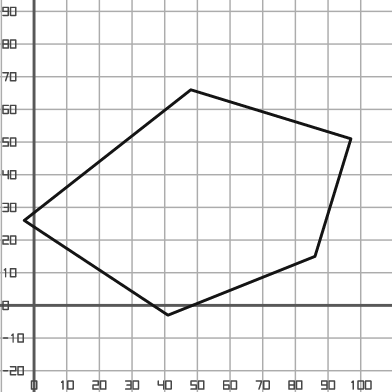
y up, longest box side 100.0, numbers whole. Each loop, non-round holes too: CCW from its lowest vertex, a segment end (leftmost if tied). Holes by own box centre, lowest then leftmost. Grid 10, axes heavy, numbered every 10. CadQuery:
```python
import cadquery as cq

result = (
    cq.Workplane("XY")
    .moveTo(41.0, -3.0)
    .lineTo(86.0, 15.0)
    .lineTo(97.0, 51.0)
    .lineTo(48.0, 66.0)
    .lineTo(-3.0, 26.0)
    .close()
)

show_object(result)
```